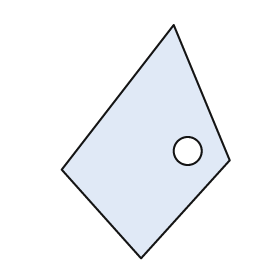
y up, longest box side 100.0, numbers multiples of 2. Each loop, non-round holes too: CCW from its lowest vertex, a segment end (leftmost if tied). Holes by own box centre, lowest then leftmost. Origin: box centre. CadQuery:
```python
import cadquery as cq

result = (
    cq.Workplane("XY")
    .moveTo(-2.0, -50.0)
    .lineTo(36.0, -8.0)
    .lineTo(12.0, 50.0)
    .lineTo(-36.0, -12.0)
    .close()
    .moveTo(18.0, -4.0)
    .circle(6.0)
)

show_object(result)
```